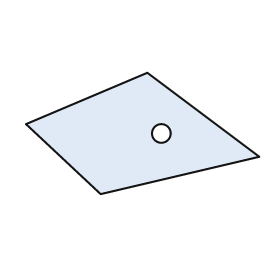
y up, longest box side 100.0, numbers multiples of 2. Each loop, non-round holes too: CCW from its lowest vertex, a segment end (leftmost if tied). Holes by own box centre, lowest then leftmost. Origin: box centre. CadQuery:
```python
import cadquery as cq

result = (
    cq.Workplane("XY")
    .moveTo(-18.0, -26.0)
    .lineTo(50.0, -10.0)
    .lineTo(2.0, 26.0)
    .lineTo(-50.0, 4.0)
    .close()
    .moveTo(8.0, 0.0)
    .circle(4.0)
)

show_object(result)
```